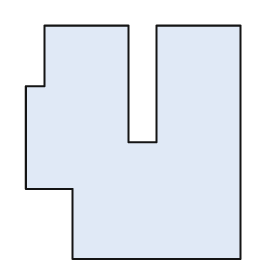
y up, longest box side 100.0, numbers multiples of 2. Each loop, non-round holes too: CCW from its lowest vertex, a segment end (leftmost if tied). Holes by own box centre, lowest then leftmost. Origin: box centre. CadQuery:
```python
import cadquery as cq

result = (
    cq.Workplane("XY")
    .moveTo(-26.0, -50.0)
    .lineTo(46.0, -50.0)
    .lineTo(46.0, 50.0)
    .lineTo(10.0, 50.0)
    .lineTo(10.0, 0.0)
    .lineTo(-2.0, 0.0)
    .lineTo(-2.0, 50.0)
    .lineTo(-38.0, 50.0)
    .lineTo(-38.0, 24.0)
    .lineTo(-46.0, 24.0)
    .lineTo(-46.0, -20.0)
    .lineTo(-26.0, -20.0)
    .close()
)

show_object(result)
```